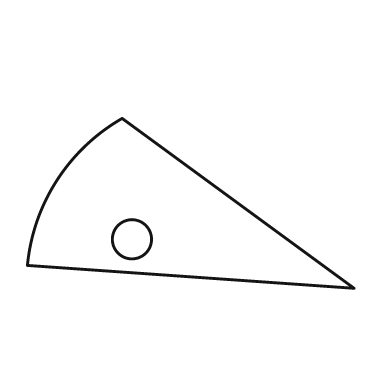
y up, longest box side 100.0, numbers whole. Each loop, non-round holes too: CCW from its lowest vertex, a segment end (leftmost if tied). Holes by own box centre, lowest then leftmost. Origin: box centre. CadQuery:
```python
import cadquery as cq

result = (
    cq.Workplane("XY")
    .moveTo(50.0, -26.0)
    .lineTo(-21.0, 26.0)
    .threePointArc((-41.0, 7.0), (-50.0, -19.0))
    .close()
    .moveTo(-18.0, -11.0)
    .circle(6.0)
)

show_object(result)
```